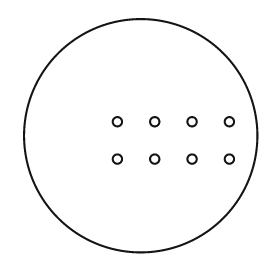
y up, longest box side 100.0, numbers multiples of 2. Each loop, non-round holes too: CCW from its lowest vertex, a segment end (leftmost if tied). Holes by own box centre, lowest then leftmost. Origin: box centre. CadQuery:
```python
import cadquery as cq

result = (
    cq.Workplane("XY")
    .moveTo(0.0, 0.0)
    .circle(50.0)
    .moveTo(-10.0, -10.0)
    .circle(2.0)
    .moveTo(6.0, -10.0)
    .circle(2.0)
    .moveTo(22.0, -10.0)
    .circle(2.0)
    .moveTo(38.0, -10.0)
    .circle(2.0)
    .moveTo(-10.0, 6.0)
    .circle(2.0)
    .moveTo(6.0, 6.0)
    .circle(2.0)
    .moveTo(22.0, 6.0)
    .circle(2.0)
    .moveTo(38.0, 6.0)
    .circle(2.0)
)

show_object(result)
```